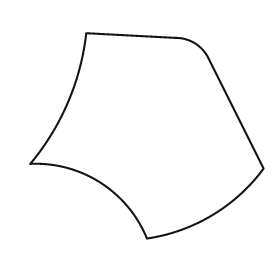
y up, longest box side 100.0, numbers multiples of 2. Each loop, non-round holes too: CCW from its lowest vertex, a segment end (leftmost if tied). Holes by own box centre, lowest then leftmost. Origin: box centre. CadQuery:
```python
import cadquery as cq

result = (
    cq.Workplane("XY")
    .moveTo(0.0, -44.0)
    .threePointArc((28.0, -34.0), (50.0, -14.0))
    .lineTo(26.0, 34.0)
    .threePointArc((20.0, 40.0), (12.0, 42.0))
    .lineTo(-26.0, 44.0)
    .threePointArc((-34.0, 14.0), (-50.0, -12.0))
    .threePointArc((-20.0, -20.0), (0.0, -44.0))
    .close()
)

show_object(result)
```